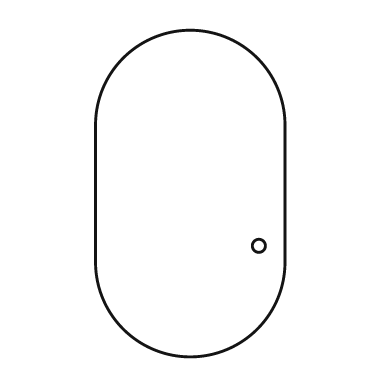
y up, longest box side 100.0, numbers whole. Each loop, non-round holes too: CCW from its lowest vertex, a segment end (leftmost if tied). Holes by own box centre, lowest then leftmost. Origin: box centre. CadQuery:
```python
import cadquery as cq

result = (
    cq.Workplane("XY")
    .moveTo(-29.0, -21.0)
    .threePointArc((0.0, -50.0), (29.0, -21.0))
    .lineTo(29.0, 21.0)
    .threePointArc((0.0, 50.0), (-29.0, 21.0))
    .close()
    .moveTo(21.0, -16.0)
    .circle(2.0)
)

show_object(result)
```